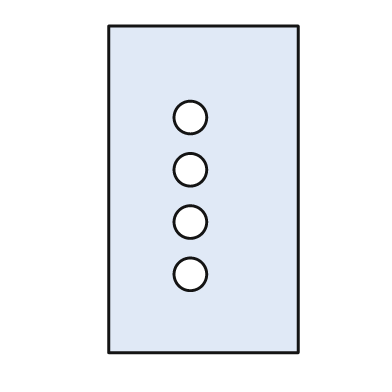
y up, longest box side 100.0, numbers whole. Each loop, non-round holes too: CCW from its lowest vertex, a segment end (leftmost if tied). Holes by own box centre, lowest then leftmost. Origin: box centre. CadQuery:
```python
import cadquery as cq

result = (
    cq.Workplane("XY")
    .moveTo(-29.0, -50.0)
    .lineTo(29.0, -50.0)
    .lineTo(29.0, 50.0)
    .lineTo(-29.0, 50.0)
    .close()
    .moveTo(-4.0, -26.0)
    .circle(5.0)
    .moveTo(-4.0, -10.0)
    .circle(5.0)
    .moveTo(-4.0, 6.0)
    .circle(5.0)
    .moveTo(-4.0, 22.0)
    .circle(5.0)
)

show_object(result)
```